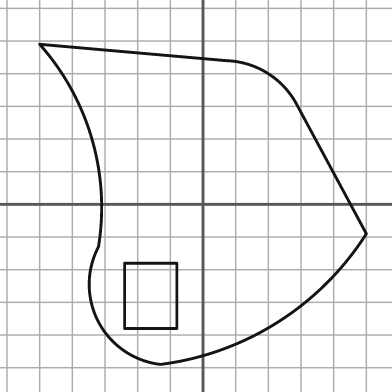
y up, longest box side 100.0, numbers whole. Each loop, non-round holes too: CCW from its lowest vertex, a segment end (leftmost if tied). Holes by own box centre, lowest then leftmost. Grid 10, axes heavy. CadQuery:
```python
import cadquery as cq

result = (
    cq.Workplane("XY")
    .moveTo(-13.0, -49.0)
    .threePointArc((23.0, -36.0), (50.0, -9.0))
    .lineTo(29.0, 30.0)
    .threePointArc((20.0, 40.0), (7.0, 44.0))
    .lineTo(-50.0, 49.0)
    .threePointArc((-34.0, 20.0), (-32.0, -13.0))
    .threePointArc((-32.0, -36.0), (-13.0, -49.0))
    .close()
    .moveTo(-24.0, -38.0)
    .lineTo(-8.0, -38.0)
    .lineTo(-8.0, -18.0)
    .lineTo(-24.0, -18.0)
    .close()
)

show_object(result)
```